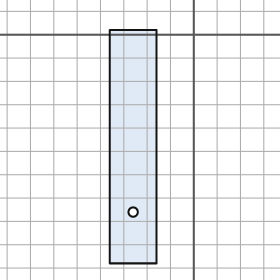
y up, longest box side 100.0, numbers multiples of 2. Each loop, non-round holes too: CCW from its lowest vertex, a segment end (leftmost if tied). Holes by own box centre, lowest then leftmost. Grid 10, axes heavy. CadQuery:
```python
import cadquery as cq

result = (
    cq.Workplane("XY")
    .moveTo(-36.0, -98.0)
    .lineTo(-16.0, -98.0)
    .lineTo(-16.0, 2.0)
    .lineTo(-36.0, 2.0)
    .close()
    .moveTo(-26.0, -76.0)
    .circle(2.0)
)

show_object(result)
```